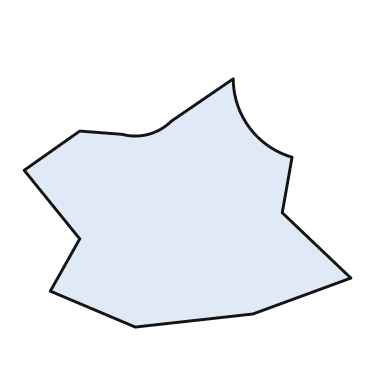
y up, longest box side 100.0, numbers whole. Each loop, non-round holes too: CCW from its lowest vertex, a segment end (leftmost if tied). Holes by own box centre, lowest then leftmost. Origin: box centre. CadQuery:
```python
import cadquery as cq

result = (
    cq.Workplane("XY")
    .moveTo(-16.0, -38.0)
    .lineTo(20.0, -34.0)
    .lineTo(50.0, -23.0)
    .lineTo(29.0, -3.0)
    .lineTo(32.0, 14.0)
    .threePointArc((19.0, 23.0), (14.0, 38.0))
    .lineTo(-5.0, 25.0)
    .threePointArc((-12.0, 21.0), (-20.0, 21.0))
    .lineTo(-33.0, 22.0)
    .lineTo(-50.0, 10.0)
    .lineTo(-33.0, -11.0)
    .lineTo(-42.0, -27.0)
    .close()
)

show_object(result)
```